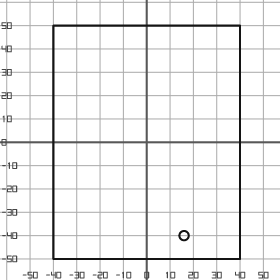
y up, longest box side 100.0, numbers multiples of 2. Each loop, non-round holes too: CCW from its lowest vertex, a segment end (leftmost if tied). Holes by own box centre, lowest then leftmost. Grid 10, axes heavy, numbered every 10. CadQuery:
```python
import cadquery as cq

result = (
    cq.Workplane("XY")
    .moveTo(-40.0, -50.0)
    .lineTo(40.0, -50.0)
    .lineTo(40.0, 50.0)
    .lineTo(-40.0, 50.0)
    .close()
    .moveTo(16.0, -40.0)
    .circle(2.0)
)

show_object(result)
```